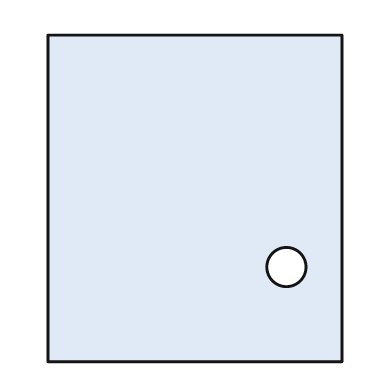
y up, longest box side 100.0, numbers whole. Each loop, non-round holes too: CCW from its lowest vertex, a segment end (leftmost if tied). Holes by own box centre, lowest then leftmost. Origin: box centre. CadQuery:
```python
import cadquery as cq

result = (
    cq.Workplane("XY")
    .moveTo(-45.0, -50.0)
    .lineTo(45.0, -50.0)
    .lineTo(45.0, 50.0)
    .lineTo(-45.0, 50.0)
    .close()
    .moveTo(28.0, -21.0)
    .circle(6.0)
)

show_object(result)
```